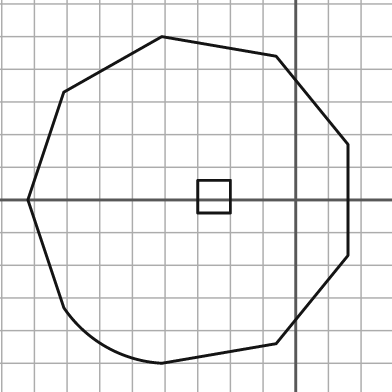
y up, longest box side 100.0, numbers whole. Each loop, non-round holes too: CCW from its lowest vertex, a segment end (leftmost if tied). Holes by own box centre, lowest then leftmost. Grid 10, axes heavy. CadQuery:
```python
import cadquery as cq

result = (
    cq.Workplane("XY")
    .moveTo(-41.0, -50.0)
    .lineTo(-6.0, -44.0)
    .lineTo(16.0, -17.0)
    .lineTo(16.0, 17.0)
    .lineTo(-6.0, 44.0)
    .lineTo(-41.0, 50.0)
    .lineTo(-71.0, 33.0)
    .lineTo(-82.0, 0.0)
    .lineTo(-71.0, -33.0)
    .threePointArc((-58.0, -45.0), (-41.0, -50.0))
    .close()
    .moveTo(-30.0, -4.0)
    .lineTo(-20.0, -4.0)
    .lineTo(-20.0, 6.0)
    .lineTo(-30.0, 6.0)
    .close()
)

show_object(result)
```